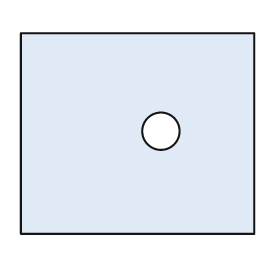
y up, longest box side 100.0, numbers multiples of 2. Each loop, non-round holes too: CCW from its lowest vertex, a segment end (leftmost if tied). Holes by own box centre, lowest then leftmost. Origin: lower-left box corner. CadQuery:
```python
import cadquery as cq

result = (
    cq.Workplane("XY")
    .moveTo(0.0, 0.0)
    .lineTo(100.0, 0.0)
    .lineTo(100.0, 86.0)
    .lineTo(0.0, 86.0)
    .close()
    .moveTo(60.0, 44.0)
    .circle(8.0)
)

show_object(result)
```